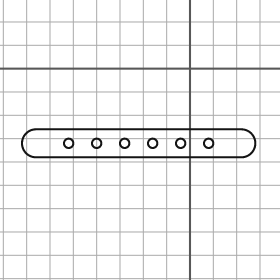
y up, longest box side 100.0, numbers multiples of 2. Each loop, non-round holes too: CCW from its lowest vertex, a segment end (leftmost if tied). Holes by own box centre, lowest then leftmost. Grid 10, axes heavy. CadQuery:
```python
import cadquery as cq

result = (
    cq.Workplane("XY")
    .moveTo(-66.0, -38.0)
    .lineTo(22.0, -38.0)
    .threePointArc((28.0, -32.0), (22.0, -26.0))
    .lineTo(-66.0, -26.0)
    .threePointArc((-72.0, -32.0), (-66.0, -38.0))
    .close()
    .moveTo(-52.0, -32.0)
    .circle(2.0)
    .moveTo(-40.0, -32.0)
    .circle(2.0)
    .moveTo(-28.0, -32.0)
    .circle(2.0)
    .moveTo(-16.0, -32.0)
    .circle(2.0)
    .moveTo(-4.0, -32.0)
    .circle(2.0)
    .moveTo(8.0, -32.0)
    .circle(2.0)
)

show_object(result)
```